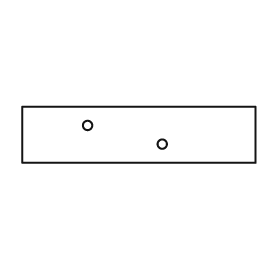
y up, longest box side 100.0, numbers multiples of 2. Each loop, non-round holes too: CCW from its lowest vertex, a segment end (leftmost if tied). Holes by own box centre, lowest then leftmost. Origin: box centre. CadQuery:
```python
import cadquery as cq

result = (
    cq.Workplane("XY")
    .moveTo(-50.0, -12.0)
    .lineTo(50.0, -12.0)
    .lineTo(50.0, 12.0)
    .lineTo(-50.0, 12.0)
    .close()
    .moveTo(10.0, -4.0)
    .circle(2.0)
    .moveTo(-22.0, 4.0)
    .circle(2.0)
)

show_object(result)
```